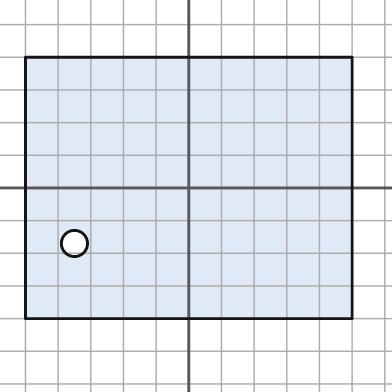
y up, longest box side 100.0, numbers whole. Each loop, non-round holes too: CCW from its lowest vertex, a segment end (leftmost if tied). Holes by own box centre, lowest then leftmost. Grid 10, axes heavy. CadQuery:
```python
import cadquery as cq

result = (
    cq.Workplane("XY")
    .moveTo(-50.0, -40.0)
    .lineTo(50.0, -40.0)
    .lineTo(50.0, 40.0)
    .lineTo(-50.0, 40.0)
    .close()
    .moveTo(-35.0, -17.0)
    .circle(4.0)
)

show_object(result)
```